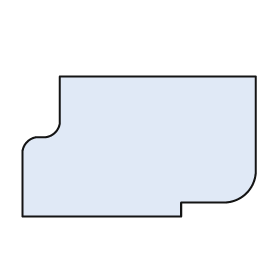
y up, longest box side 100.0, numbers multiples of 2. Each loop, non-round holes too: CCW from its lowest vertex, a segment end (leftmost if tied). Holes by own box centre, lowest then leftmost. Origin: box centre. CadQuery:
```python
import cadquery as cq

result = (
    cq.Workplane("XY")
    .moveTo(-50.0, -30.0)
    .lineTo(18.0, -30.0)
    .lineTo(18.0, -24.0)
    .lineTo(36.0, -24.0)
    .threePointArc((46.0, -20.0), (50.0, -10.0))
    .lineTo(50.0, 30.0)
    .lineTo(-34.0, 30.0)
    .lineTo(-34.0, 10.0)
    .threePointArc((-36.0, 6.0), (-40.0, 4.0))
    .lineTo(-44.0, 4.0)
    .threePointArc((-48.0, 2.0), (-50.0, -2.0))
    .close()
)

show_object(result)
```